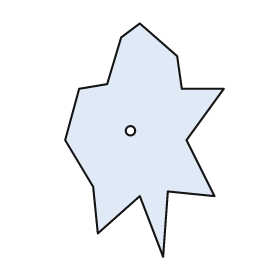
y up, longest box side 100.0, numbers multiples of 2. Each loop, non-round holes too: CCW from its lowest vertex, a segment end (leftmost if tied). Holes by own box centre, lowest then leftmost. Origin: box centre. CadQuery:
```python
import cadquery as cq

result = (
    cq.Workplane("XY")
    .moveTo(8.0, -50.0)
    .lineTo(10.0, -22.0)
    .lineTo(30.0, -24.0)
    .lineTo(18.0, 0.0)
    .lineTo(34.0, 22.0)
    .lineTo(16.0, 22.0)
    .lineTo(14.0, 36.0)
    .lineTo(-2.0, 50.0)
    .lineTo(-10.0, 44.0)
    .lineTo(-16.0, 24.0)
    .lineTo(-28.0, 22.0)
    .lineTo(-34.0, 0.0)
    .lineTo(-22.0, -20.0)
    .lineTo(-20.0, -40.0)
    .lineTo(-2.0, -24.0)
    .close()
    .moveTo(-6.0, 4.0)
    .circle(2.0)
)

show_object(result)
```